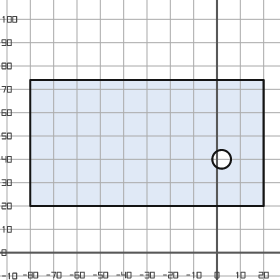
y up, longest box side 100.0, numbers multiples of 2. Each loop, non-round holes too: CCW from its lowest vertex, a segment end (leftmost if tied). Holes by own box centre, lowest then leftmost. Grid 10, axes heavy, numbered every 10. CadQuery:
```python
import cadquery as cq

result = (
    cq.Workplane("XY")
    .moveTo(-80.0, 20.0)
    .lineTo(20.0, 20.0)
    .lineTo(20.0, 74.0)
    .lineTo(-80.0, 74.0)
    .close()
    .moveTo(2.0, 40.0)
    .circle(4.0)
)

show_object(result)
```